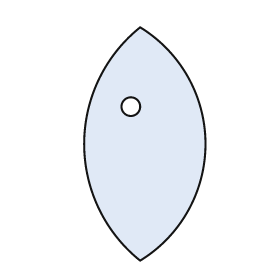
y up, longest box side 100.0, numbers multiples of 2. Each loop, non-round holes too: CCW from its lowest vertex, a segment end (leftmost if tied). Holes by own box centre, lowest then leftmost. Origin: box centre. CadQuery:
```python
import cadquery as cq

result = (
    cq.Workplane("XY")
    .moveTo(-2.0, -50.0)
    .threePointArc((26.0, 0.0), (-2.0, 50.0))
    .threePointArc((-26.0, 0.0), (-2.0, -50.0))
    .close()
    .moveTo(-6.0, 16.0)
    .circle(4.0)
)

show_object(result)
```